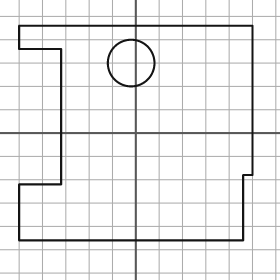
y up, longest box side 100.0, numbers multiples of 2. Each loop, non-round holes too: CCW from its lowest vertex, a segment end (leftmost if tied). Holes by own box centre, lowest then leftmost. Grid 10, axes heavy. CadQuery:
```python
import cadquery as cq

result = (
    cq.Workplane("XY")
    .moveTo(-50.0, -46.0)
    .lineTo(46.0, -46.0)
    .lineTo(46.0, -18.0)
    .lineTo(50.0, -18.0)
    .lineTo(50.0, 46.0)
    .lineTo(-50.0, 46.0)
    .lineTo(-50.0, 36.0)
    .lineTo(-32.0, 36.0)
    .lineTo(-32.0, -22.0)
    .lineTo(-50.0, -22.0)
    .close()
    .moveTo(-2.0, 30.0)
    .circle(10.0)
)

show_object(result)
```